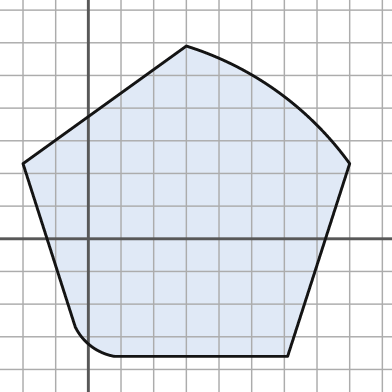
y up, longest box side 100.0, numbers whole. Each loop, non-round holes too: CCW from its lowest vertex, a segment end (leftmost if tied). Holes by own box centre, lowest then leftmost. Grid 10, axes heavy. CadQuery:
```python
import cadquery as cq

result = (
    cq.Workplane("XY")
    .moveTo(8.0, -36.0)
    .lineTo(61.0, -36.0)
    .lineTo(80.0, 23.0)
    .threePointArc((58.0, 45.0), (30.0, 59.0))
    .lineTo(-20.0, 23.0)
    .lineTo(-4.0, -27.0)
    .threePointArc((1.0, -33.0), (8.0, -36.0))
    .close()
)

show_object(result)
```